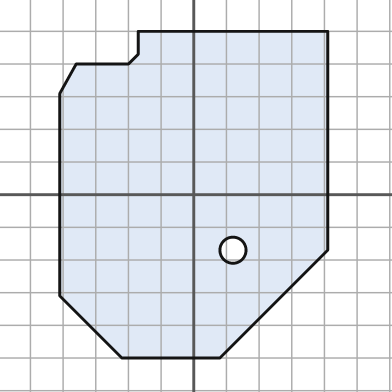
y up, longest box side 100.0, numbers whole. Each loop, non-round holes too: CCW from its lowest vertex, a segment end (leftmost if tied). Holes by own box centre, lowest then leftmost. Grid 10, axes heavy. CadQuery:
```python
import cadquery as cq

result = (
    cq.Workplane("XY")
    .moveTo(-22.0, -50.0)
    .lineTo(8.0, -50.0)
    .lineTo(41.0, -17.0)
    .lineTo(41.0, 50.0)
    .lineTo(-17.0, 50.0)
    .lineTo(-17.0, 43.0)
    .lineTo(-20.0, 40.0)
    .lineTo(-36.0, 40.0)
    .lineTo(-41.0, 31.0)
    .lineTo(-41.0, -31.0)
    .close()
    .moveTo(12.0, -17.0)
    .circle(4.0)
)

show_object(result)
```